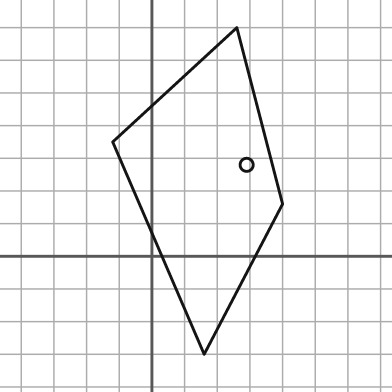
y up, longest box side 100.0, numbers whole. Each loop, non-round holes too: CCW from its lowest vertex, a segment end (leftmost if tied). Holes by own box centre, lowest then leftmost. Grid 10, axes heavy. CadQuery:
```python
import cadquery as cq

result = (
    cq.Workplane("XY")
    .moveTo(16.0, -30.0)
    .lineTo(40.0, 16.0)
    .lineTo(26.0, 70.0)
    .lineTo(-12.0, 35.0)
    .close()
    .moveTo(29.0, 28.0)
    .circle(2.0)
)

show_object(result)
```